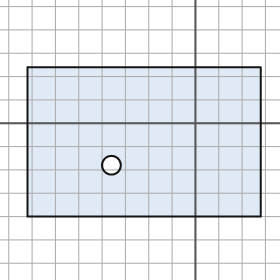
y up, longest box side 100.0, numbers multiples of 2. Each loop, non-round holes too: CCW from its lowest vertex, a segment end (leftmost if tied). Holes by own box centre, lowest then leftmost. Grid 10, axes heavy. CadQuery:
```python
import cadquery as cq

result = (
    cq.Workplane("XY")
    .moveTo(-72.0, -40.0)
    .lineTo(28.0, -40.0)
    .lineTo(28.0, 24.0)
    .lineTo(-72.0, 24.0)
    .close()
    .moveTo(-36.0, -18.0)
    .circle(4.0)
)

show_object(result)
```